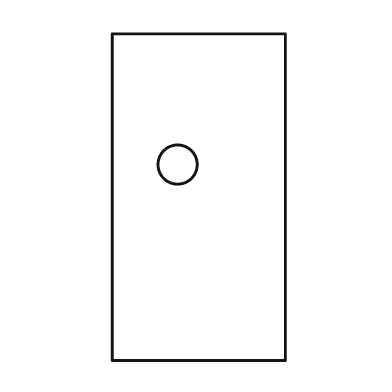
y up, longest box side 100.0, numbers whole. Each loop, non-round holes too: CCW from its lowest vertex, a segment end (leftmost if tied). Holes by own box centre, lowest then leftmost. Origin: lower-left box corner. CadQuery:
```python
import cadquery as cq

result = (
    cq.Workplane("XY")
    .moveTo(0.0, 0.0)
    .lineTo(53.0, 0.0)
    .lineTo(53.0, 100.0)
    .lineTo(0.0, 100.0)
    .close()
    .moveTo(20.0, 60.0)
    .circle(6.0)
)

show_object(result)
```